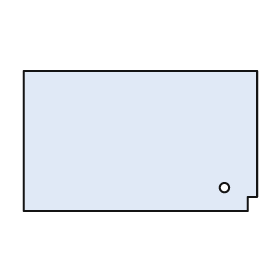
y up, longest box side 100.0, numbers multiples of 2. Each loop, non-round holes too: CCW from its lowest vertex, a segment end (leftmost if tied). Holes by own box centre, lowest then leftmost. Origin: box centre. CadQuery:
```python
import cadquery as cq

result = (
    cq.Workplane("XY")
    .moveTo(-50.0, -30.0)
    .lineTo(46.0, -30.0)
    .lineTo(46.0, -24.0)
    .lineTo(50.0, -24.0)
    .lineTo(50.0, 30.0)
    .lineTo(-50.0, 30.0)
    .close()
    .moveTo(36.0, -20.0)
    .circle(2.0)
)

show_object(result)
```